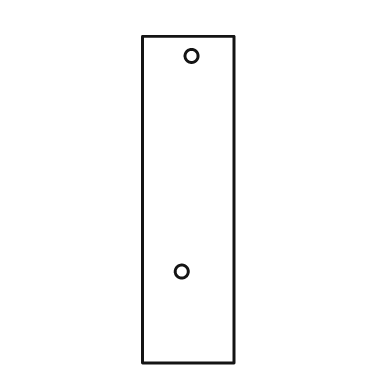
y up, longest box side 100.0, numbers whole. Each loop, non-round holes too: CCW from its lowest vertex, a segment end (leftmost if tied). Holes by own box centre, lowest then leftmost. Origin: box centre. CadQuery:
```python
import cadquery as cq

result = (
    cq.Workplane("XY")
    .moveTo(-14.0, -50.0)
    .lineTo(14.0, -50.0)
    .lineTo(14.0, 50.0)
    .lineTo(-14.0, 50.0)
    .close()
    .moveTo(-2.0, -22.0)
    .circle(2.0)
    .moveTo(1.0, 44.0)
    .circle(2.0)
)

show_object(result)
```